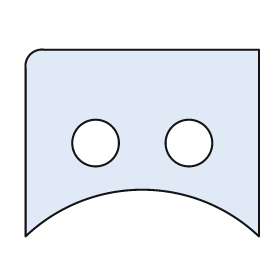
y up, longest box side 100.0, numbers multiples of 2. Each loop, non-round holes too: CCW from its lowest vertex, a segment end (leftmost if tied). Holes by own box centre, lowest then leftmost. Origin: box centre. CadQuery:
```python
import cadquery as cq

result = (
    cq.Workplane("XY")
    .moveTo(-50.0, -40.0)
    .threePointArc((0.0, -20.0), (50.0, -40.0))
    .lineTo(50.0, 40.0)
    .lineTo(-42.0, 40.0)
    .threePointArc((-48.0, 38.0), (-50.0, 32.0))
    .close()
    .moveTo(-20.0, 0.0)
    .circle(10.0)
    .moveTo(20.0, 0.0)
    .circle(10.0)
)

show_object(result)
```